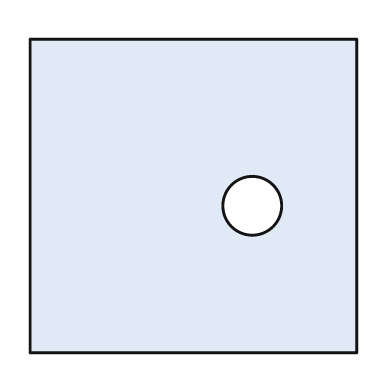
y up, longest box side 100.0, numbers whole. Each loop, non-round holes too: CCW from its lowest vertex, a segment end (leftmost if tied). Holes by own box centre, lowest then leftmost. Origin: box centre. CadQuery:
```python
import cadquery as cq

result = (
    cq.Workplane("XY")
    .moveTo(-50.0, -48.0)
    .lineTo(50.0, -48.0)
    .lineTo(50.0, 48.0)
    .lineTo(-50.0, 48.0)
    .close()
    .moveTo(18.0, -3.0)
    .circle(9.0)
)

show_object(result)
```